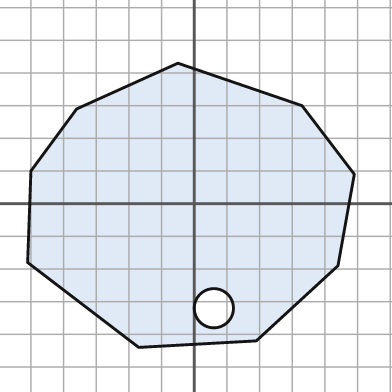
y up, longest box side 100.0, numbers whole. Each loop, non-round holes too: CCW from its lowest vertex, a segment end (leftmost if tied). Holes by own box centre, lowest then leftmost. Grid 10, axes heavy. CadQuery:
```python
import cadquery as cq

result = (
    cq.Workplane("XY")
    .moveTo(-17.0, -44.0)
    .lineTo(19.0, -42.0)
    .lineTo(44.0, -19.0)
    .lineTo(49.0, 9.0)
    .lineTo(33.0, 30.0)
    .lineTo(-5.0, 43.0)
    .lineTo(-36.0, 29.0)
    .lineTo(-50.0, 10.0)
    .lineTo(-51.0, -18.0)
    .close()
    .moveTo(6.0, -32.0)
    .circle(6.0)
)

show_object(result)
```